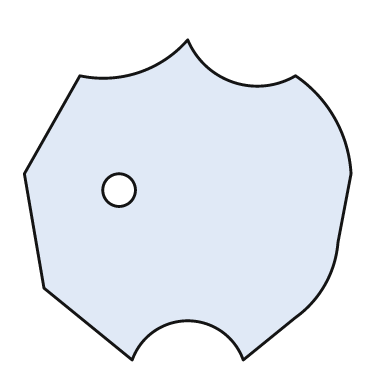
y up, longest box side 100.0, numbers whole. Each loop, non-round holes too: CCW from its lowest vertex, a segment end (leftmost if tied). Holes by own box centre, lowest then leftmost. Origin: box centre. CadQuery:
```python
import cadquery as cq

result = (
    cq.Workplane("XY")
    .moveTo(-17.0, -49.0)
    .threePointArc((0.0, -37.0), (17.0, -49.0))
    .lineTo(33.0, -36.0)
    .threePointArc((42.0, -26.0), (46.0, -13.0))
    .lineTo(50.0, 8.0)
    .threePointArc((45.0, 25.0), (33.0, 38.0))
    .threePointArc((14.0, 36.0), (0.0, 49.0))
    .threePointArc((-15.0, 39.0), (-33.0, 38.0))
    .lineTo(-50.0, 8.0)
    .lineTo(-44.0, -27.0)
    .close()
    .moveTo(-21.0, 3.0)
    .circle(5.0)
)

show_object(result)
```